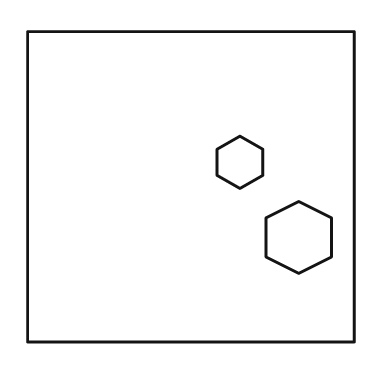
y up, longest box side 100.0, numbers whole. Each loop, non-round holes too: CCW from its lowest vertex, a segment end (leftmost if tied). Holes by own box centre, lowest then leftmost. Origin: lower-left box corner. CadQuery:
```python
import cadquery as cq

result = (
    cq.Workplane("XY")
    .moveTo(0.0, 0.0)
    .lineTo(100.0, 0.0)
    .lineTo(100.0, 95.0)
    .lineTo(0.0, 95.0)
    .close()
    .moveTo(83.0, 21.0)
    .lineTo(93.0, 26.0)
    .lineTo(93.0, 38.0)
    .lineTo(83.0, 43.0)
    .lineTo(73.0, 38.0)
    .lineTo(73.0, 26.0)
    .close()
    .moveTo(65.0, 47.0)
    .lineTo(72.0, 51.0)
    .lineTo(72.0, 59.0)
    .lineTo(65.0, 63.0)
    .lineTo(58.0, 59.0)
    .lineTo(58.0, 51.0)
    .close()
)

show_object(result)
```